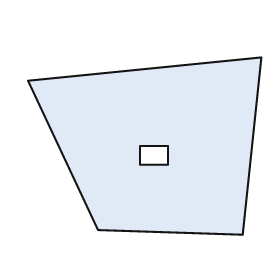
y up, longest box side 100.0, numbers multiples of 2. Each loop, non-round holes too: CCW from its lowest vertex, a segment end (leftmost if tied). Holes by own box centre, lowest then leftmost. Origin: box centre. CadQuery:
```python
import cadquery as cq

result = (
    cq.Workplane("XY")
    .moveTo(42.0, -38.0)
    .lineTo(50.0, 38.0)
    .lineTo(-50.0, 28.0)
    .lineTo(-20.0, -36.0)
    .close()
    .moveTo(-2.0, -8.0)
    .lineTo(10.0, -8.0)
    .lineTo(10.0, 0.0)
    .lineTo(-2.0, 0.0)
    .close()
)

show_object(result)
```